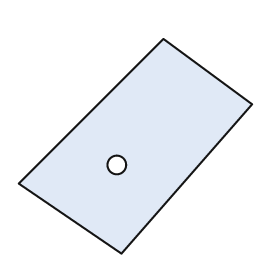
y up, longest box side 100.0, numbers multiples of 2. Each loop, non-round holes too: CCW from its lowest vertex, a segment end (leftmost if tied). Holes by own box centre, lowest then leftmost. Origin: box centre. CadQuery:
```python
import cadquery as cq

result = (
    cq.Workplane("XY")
    .moveTo(-6.0, -46.0)
    .lineTo(50.0, 18.0)
    .lineTo(12.0, 46.0)
    .lineTo(-50.0, -16.0)
    .close()
    .moveTo(-8.0, -8.0)
    .circle(4.0)
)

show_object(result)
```